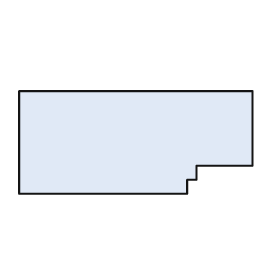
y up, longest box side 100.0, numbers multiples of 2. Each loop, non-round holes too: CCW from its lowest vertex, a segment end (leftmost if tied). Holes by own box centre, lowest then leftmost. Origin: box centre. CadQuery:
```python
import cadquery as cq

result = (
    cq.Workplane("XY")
    .moveTo(-50.0, -22.0)
    .lineTo(22.0, -22.0)
    .lineTo(22.0, -16.0)
    .lineTo(26.0, -16.0)
    .lineTo(26.0, -10.0)
    .lineTo(50.0, -10.0)
    .lineTo(50.0, 22.0)
    .lineTo(-50.0, 22.0)
    .close()
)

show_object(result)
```